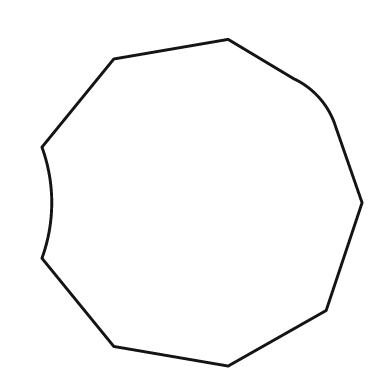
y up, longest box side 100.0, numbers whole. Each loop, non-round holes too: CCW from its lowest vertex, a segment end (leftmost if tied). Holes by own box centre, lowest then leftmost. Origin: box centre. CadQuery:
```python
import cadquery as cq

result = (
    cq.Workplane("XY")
    .moveTo(8.0, -50.0)
    .lineTo(38.0, -33.0)
    .lineTo(49.0, 0.0)
    .lineTo(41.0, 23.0)
    .threePointArc((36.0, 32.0), (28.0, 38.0))
    .lineTo(8.0, 50.0)
    .lineTo(-27.0, 44.0)
    .lineTo(-49.0, 17.0)
    .threePointArc((-46.0, 0.0), (-49.0, -17.0))
    .lineTo(-27.0, -44.0)
    .close()
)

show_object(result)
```